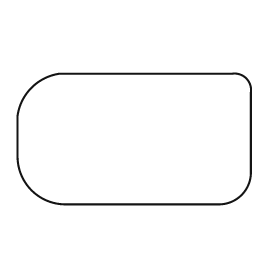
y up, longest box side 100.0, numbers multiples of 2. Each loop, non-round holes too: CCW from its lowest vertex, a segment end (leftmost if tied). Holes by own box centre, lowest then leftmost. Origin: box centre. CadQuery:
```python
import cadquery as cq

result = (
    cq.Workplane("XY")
    .moveTo(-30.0, -28.0)
    .lineTo(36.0, -28.0)
    .threePointArc((46.0, -24.0), (50.0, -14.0))
    .lineTo(50.0, 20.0)
    .threePointArc((48.0, 26.0), (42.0, 28.0))
    .lineTo(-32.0, 28.0)
    .threePointArc((-44.0, 22.0), (-50.0, 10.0))
    .lineTo(-50.0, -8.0)
    .threePointArc((-44.0, -22.0), (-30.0, -28.0))
    .close()
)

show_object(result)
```